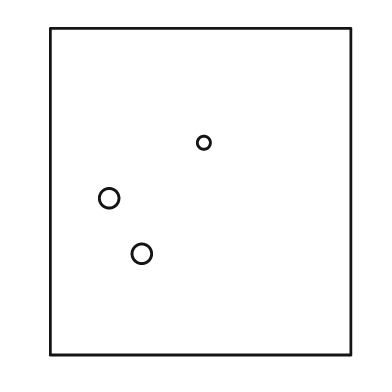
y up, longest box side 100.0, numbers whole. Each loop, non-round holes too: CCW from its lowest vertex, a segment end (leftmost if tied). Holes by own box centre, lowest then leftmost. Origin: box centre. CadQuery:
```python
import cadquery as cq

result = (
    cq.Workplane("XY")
    .moveTo(-46.0, -50.0)
    .lineTo(46.0, -50.0)
    .lineTo(46.0, 50.0)
    .lineTo(-46.0, 50.0)
    .close()
    .moveTo(-18.0, -19.0)
    .circle(3.0)
    .moveTo(-28.0, -2.0)
    .circle(3.0)
    .moveTo(1.0, 15.0)
    .circle(2.0)
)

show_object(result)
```